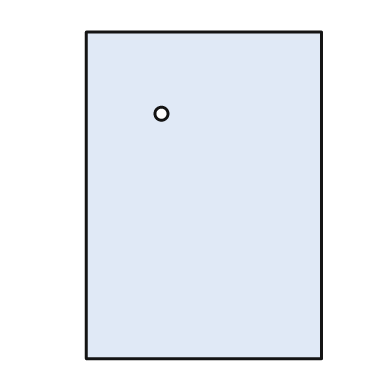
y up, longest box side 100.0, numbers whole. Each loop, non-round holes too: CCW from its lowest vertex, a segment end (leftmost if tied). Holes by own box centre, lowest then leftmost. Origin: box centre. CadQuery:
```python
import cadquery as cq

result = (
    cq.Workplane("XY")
    .moveTo(-36.0, -50.0)
    .lineTo(36.0, -50.0)
    .lineTo(36.0, 50.0)
    .lineTo(-36.0, 50.0)
    .close()
    .moveTo(-13.0, 25.0)
    .circle(2.0)
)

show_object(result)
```